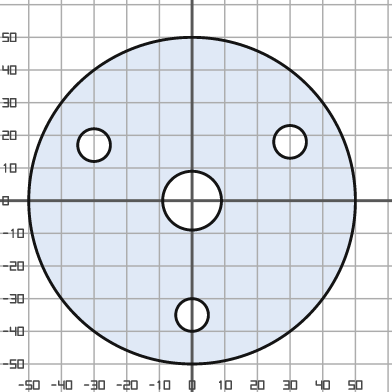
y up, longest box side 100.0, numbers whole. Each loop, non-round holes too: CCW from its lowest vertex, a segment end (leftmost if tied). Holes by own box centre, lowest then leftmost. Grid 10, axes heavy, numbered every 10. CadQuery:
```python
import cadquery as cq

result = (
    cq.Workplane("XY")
    .moveTo(0.0, 0.0)
    .circle(50.0)
    .moveTo(0.0, -35.0)
    .circle(5.0)
    .moveTo(0.0, 0.0)
    .circle(9.0)
    .moveTo(-30.0, 17.0)
    .circle(5.0)
    .moveTo(30.0, 18.0)
    .circle(5.0)
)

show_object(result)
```